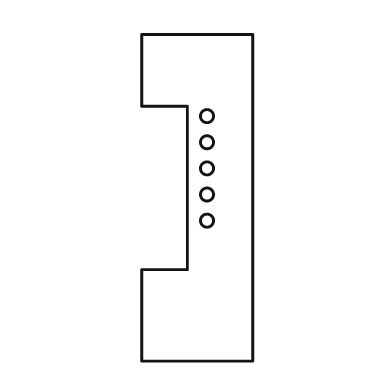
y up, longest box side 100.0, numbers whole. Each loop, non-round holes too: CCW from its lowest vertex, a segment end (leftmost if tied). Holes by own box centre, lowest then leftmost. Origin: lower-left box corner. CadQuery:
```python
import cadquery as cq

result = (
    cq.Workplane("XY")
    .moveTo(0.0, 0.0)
    .lineTo(34.0, 0.0)
    .lineTo(34.0, 100.0)
    .lineTo(0.0, 100.0)
    .lineTo(0.0, 78.0)
    .lineTo(14.0, 78.0)
    .lineTo(14.0, 28.0)
    .lineTo(0.0, 28.0)
    .close()
    .moveTo(20.0, 43.0)
    .circle(2.0)
    .moveTo(20.0, 51.0)
    .circle(2.0)
    .moveTo(20.0, 59.0)
    .circle(2.0)
    .moveTo(20.0, 67.0)
    .circle(2.0)
    .moveTo(20.0, 75.0)
    .circle(2.0)
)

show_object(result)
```